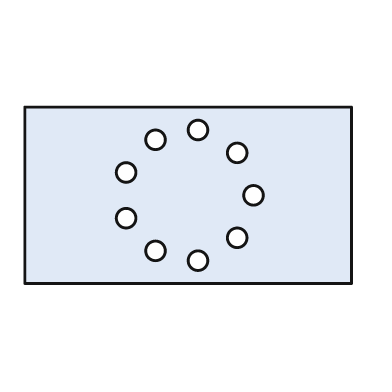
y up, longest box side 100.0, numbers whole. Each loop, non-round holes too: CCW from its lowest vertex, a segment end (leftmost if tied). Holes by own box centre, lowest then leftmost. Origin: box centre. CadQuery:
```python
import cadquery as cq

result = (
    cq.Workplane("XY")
    .moveTo(-50.0, -27.0)
    .lineTo(50.0, -27.0)
    .lineTo(50.0, 27.0)
    .lineTo(-50.0, 27.0)
    .close()
    .moveTo(3.0, -20.0)
    .circle(3.0)
    .moveTo(-10.0, -17.0)
    .circle(3.0)
    .moveTo(15.0, -13.0)
    .circle(3.0)
    .moveTo(-19.0, -7.0)
    .circle(3.0)
    .moveTo(20.0, 0.0)
    .circle(3.0)
    .moveTo(-19.0, 7.0)
    .circle(3.0)
    .moveTo(15.0, 13.0)
    .circle(3.0)
    .moveTo(-10.0, 17.0)
    .circle(3.0)
    .moveTo(3.0, 20.0)
    .circle(3.0)
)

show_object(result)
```